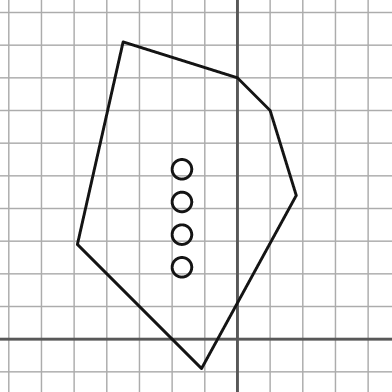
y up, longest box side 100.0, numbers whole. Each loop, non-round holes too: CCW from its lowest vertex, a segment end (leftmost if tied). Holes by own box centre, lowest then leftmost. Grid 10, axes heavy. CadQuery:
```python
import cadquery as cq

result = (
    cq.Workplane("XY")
    .moveTo(-11.0, -9.0)
    .lineTo(18.0, 44.0)
    .lineTo(10.0, 70.0)
    .lineTo(0.0, 80.0)
    .lineTo(-35.0, 91.0)
    .lineTo(-49.0, 29.0)
    .close()
    .moveTo(-17.0, 22.0)
    .circle(3.0)
    .moveTo(-17.0, 32.0)
    .circle(3.0)
    .moveTo(-17.0, 42.0)
    .circle(3.0)
    .moveTo(-17.0, 52.0)
    .circle(3.0)
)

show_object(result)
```